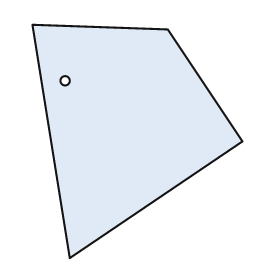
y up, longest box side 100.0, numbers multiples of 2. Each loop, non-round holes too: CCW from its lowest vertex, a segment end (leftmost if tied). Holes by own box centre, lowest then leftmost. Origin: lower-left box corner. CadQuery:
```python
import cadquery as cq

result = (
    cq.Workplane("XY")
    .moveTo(16.0, 0.0)
    .lineTo(90.0, 50.0)
    .lineTo(58.0, 98.0)
    .lineTo(0.0, 100.0)
    .close()
    .moveTo(14.0, 76.0)
    .circle(2.0)
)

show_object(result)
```